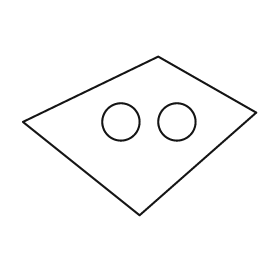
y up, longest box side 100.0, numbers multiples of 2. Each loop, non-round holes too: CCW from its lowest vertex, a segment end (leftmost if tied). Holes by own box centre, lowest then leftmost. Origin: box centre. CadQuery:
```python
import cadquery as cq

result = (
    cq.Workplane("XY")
    .moveTo(0.0, -34.0)
    .lineTo(50.0, 10.0)
    .lineTo(8.0, 34.0)
    .lineTo(-50.0, 6.0)
    .close()
    .moveTo(-8.0, 6.0)
    .circle(8.0)
    .moveTo(16.0, 6.0)
    .circle(8.0)
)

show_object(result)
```